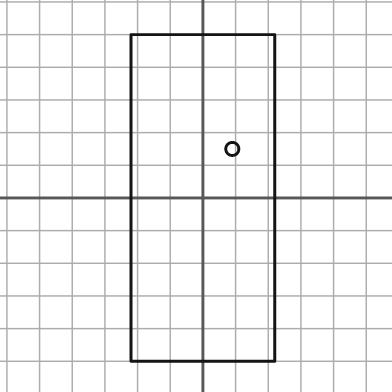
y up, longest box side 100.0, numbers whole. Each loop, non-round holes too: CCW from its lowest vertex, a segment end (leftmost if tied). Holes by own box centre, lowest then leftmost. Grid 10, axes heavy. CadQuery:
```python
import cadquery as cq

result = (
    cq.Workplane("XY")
    .moveTo(-22.0, -50.0)
    .lineTo(22.0, -50.0)
    .lineTo(22.0, 50.0)
    .lineTo(-22.0, 50.0)
    .close()
    .moveTo(9.0, 15.0)
    .circle(2.0)
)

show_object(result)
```